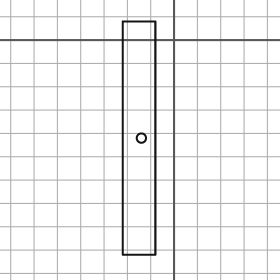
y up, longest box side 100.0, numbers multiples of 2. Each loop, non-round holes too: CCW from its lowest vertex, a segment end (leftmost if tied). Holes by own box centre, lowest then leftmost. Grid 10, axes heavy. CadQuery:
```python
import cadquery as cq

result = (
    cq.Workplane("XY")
    .moveTo(-22.0, -92.0)
    .lineTo(-8.0, -92.0)
    .lineTo(-8.0, 8.0)
    .lineTo(-22.0, 8.0)
    .close()
    .moveTo(-14.0, -42.0)
    .circle(2.0)
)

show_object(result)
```